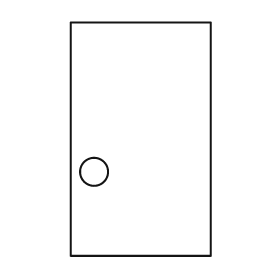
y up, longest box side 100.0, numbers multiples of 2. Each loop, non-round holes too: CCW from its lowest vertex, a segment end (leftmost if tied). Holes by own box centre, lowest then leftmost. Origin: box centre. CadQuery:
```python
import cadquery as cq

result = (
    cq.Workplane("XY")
    .moveTo(-30.0, -50.0)
    .lineTo(30.0, -50.0)
    .lineTo(30.0, 50.0)
    .lineTo(-30.0, 50.0)
    .close()
    .moveTo(-20.0, -14.0)
    .circle(6.0)
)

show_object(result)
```